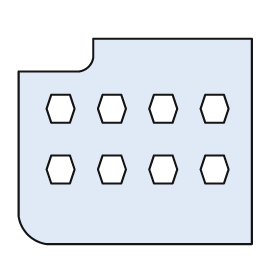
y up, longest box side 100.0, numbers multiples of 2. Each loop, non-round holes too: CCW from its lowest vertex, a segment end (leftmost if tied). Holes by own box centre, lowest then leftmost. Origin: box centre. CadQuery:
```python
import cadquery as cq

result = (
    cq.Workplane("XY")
    .moveTo(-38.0, -44.0)
    .lineTo(50.0, -44.0)
    .lineTo(50.0, 44.0)
    .lineTo(-18.0, 44.0)
    .lineTo(-18.0, 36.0)
    .threePointArc((-20.0, 32.0), (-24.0, 30.0))
    .lineTo(-50.0, 30.0)
    .lineTo(-50.0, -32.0)
    .threePointArc((-46.0, -40.0), (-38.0, -44.0))
    .close()
    .moveTo(-36.0, -18.0)
    .lineTo(-28.0, -18.0)
    .lineTo(-26.0, -12.0)
    .lineTo(-28.0, -6.0)
    .lineTo(-36.0, -6.0)
    .lineTo(-38.0, -12.0)
    .close()
    .moveTo(-14.0, -18.0)
    .lineTo(-6.0, -18.0)
    .lineTo(-4.0, -12.0)
    .lineTo(-6.0, -6.0)
    .lineTo(-14.0, -6.0)
    .lineTo(-16.0, -12.0)
    .close()
    .moveTo(8.0, -18.0)
    .lineTo(16.0, -18.0)
    .lineTo(18.0, -12.0)
    .lineTo(16.0, -6.0)
    .lineTo(8.0, -6.0)
    .lineTo(6.0, -12.0)
    .close()
    .moveTo(30.0, -18.0)
    .lineTo(38.0, -18.0)
    .lineTo(40.0, -12.0)
    .lineTo(38.0, -6.0)
    .lineTo(30.0, -6.0)
    .lineTo(28.0, -12.0)
    .close()
    .moveTo(-36.0, 8.0)
    .lineTo(-28.0, 8.0)
    .lineTo(-26.0, 14.0)
    .lineTo(-28.0, 20.0)
    .lineTo(-36.0, 20.0)
    .lineTo(-38.0, 14.0)
    .close()
    .moveTo(-14.0, 8.0)
    .lineTo(-6.0, 8.0)
    .lineTo(-4.0, 14.0)
    .lineTo(-6.0, 20.0)
    .lineTo(-14.0, 20.0)
    .lineTo(-16.0, 14.0)
    .close()
    .moveTo(8.0, 8.0)
    .lineTo(16.0, 8.0)
    .lineTo(18.0, 14.0)
    .lineTo(16.0, 20.0)
    .lineTo(8.0, 20.0)
    .lineTo(6.0, 14.0)
    .close()
    .moveTo(30.0, 8.0)
    .lineTo(38.0, 8.0)
    .lineTo(40.0, 14.0)
    .lineTo(38.0, 20.0)
    .lineTo(30.0, 20.0)
    .lineTo(28.0, 14.0)
    .close()
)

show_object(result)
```